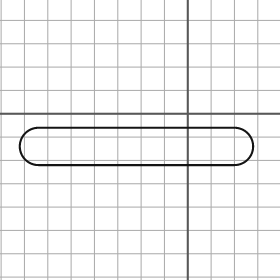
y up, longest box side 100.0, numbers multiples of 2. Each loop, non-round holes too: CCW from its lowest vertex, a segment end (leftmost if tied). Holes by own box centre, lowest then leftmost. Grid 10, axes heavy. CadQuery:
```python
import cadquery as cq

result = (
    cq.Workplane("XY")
    .moveTo(-64.0, -22.0)
    .lineTo(20.0, -22.0)
    .threePointArc((28.0, -14.0), (20.0, -6.0))
    .lineTo(-64.0, -6.0)
    .threePointArc((-72.0, -14.0), (-64.0, -22.0))
    .close()
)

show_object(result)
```